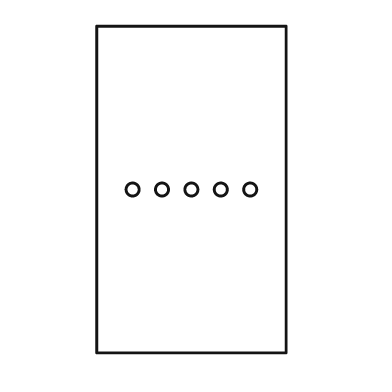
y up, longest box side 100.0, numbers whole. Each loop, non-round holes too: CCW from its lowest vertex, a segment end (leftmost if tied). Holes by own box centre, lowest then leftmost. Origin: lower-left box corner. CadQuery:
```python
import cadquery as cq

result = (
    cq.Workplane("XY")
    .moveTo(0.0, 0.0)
    .lineTo(58.0, 0.0)
    .lineTo(58.0, 100.0)
    .lineTo(0.0, 100.0)
    .close()
    .moveTo(11.0, 50.0)
    .circle(2.0)
    .moveTo(20.0, 50.0)
    .circle(2.0)
    .moveTo(29.0, 50.0)
    .circle(2.0)
    .moveTo(38.0, 50.0)
    .circle(2.0)
    .moveTo(47.0, 50.0)
    .circle(2.0)
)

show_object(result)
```